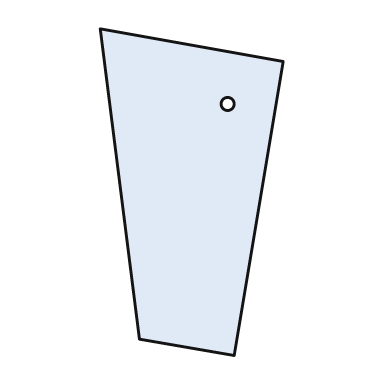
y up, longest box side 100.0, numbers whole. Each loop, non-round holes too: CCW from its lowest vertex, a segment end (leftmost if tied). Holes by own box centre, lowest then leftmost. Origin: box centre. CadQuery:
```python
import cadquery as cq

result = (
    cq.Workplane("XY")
    .moveTo(13.0, -50.0)
    .lineTo(28.0, 40.0)
    .lineTo(-28.0, 50.0)
    .lineTo(-16.0, -45.0)
    .close()
    .moveTo(11.0, 27.0)
    .circle(2.0)
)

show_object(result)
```